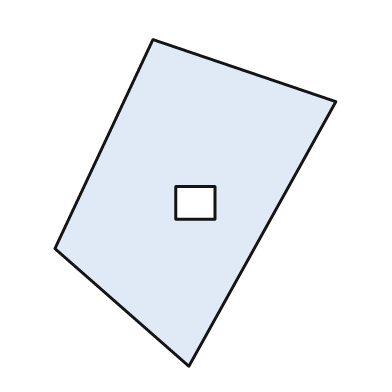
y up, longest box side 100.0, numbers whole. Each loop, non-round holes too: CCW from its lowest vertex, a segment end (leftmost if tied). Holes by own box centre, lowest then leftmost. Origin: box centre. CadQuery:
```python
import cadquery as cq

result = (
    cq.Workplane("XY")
    .moveTo(-2.0, -50.0)
    .lineTo(43.0, 31.0)
    .lineTo(-13.0, 50.0)
    .lineTo(-43.0, -14.0)
    .close()
    .moveTo(-6.0, -5.0)
    .lineTo(6.0, -5.0)
    .lineTo(6.0, 5.0)
    .lineTo(-6.0, 5.0)
    .close()
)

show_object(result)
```